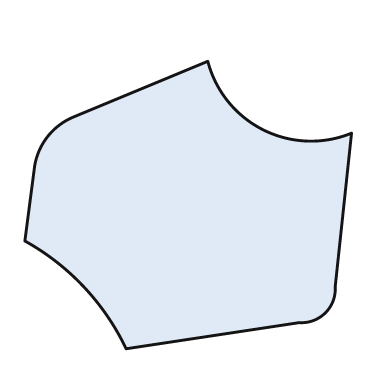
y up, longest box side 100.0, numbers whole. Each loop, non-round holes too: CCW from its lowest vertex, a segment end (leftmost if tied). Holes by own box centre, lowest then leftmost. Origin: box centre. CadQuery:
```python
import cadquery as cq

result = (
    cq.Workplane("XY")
    .moveTo(-19.0, -44.0)
    .lineTo(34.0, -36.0)
    .threePointArc((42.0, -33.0), (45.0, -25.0))
    .lineTo(50.0, 22.0)
    .threePointArc((23.0, 23.0), (6.0, 44.0))
    .lineTo(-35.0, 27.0)
    .threePointArc((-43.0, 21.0), (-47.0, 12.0))
    .lineTo(-50.0, -11.0)
    .threePointArc((-32.0, -25.0), (-19.0, -44.0))
    .close()
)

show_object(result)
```